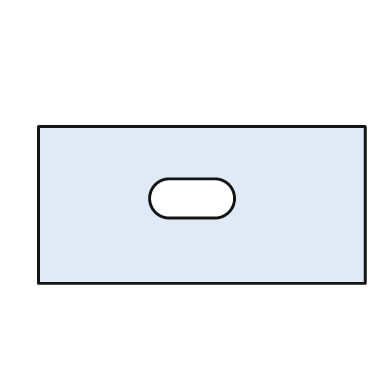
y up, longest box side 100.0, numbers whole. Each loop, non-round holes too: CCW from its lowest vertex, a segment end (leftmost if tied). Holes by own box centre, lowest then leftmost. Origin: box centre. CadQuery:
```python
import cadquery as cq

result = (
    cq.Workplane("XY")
    .moveTo(-50.0, -24.0)
    .lineTo(50.0, -24.0)
    .lineTo(50.0, 24.0)
    .lineTo(-50.0, 24.0)
    .close()
    .moveTo(-10.0, -4.0)
    .lineTo(4.0, -4.0)
    .threePointArc((10.0, 2.0), (4.0, 8.0))
    .lineTo(-10.0, 8.0)
    .threePointArc((-16.0, 2.0), (-10.0, -4.0))
    .close()
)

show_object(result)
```